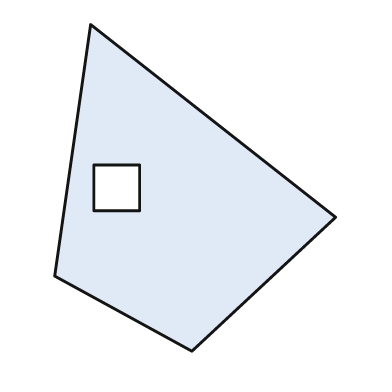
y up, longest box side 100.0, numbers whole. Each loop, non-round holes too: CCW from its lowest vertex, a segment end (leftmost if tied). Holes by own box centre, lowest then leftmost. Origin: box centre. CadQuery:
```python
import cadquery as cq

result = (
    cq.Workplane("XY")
    .moveTo(-1.0, -50.0)
    .lineTo(43.0, -9.0)
    .lineTo(-32.0, 50.0)
    .lineTo(-43.0, -27.0)
    .close()
    .moveTo(-31.0, -7.0)
    .lineTo(-17.0, -7.0)
    .lineTo(-17.0, 7.0)
    .lineTo(-31.0, 7.0)
    .close()
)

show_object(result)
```